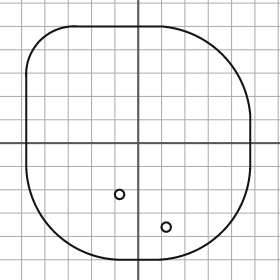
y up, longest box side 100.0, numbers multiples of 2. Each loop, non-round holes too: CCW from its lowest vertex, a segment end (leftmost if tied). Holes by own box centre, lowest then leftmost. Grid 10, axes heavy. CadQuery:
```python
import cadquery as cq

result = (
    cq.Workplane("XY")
    .moveTo(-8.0, -50.0)
    .lineTo(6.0, -50.0)
    .threePointArc((36.0, -38.0), (48.0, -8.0))
    .lineTo(48.0, 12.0)
    .threePointArc((36.0, 38.0), (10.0, 50.0))
    .lineTo(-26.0, 50.0)
    .threePointArc((-42.0, 44.0), (-48.0, 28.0))
    .lineTo(-48.0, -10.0)
    .threePointArc((-36.0, -38.0), (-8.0, -50.0))
    .close()
    .moveTo(12.0, -36.0)
    .circle(2.0)
    .moveTo(-8.0, -22.0)
    .circle(2.0)
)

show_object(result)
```